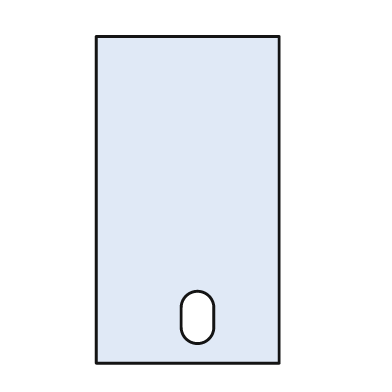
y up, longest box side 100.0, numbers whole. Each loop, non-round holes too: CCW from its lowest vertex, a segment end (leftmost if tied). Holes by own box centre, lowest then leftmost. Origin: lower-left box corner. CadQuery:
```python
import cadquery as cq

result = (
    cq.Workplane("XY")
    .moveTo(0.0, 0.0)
    .lineTo(56.0, 0.0)
    .lineTo(56.0, 100.0)
    .lineTo(0.0, 100.0)
    .close()
    .moveTo(26.0, 11.0)
    .threePointArc((31.0, 6.0), (36.0, 11.0))
    .lineTo(36.0, 17.0)
    .threePointArc((31.0, 22.0), (26.0, 17.0))
    .close()
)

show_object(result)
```